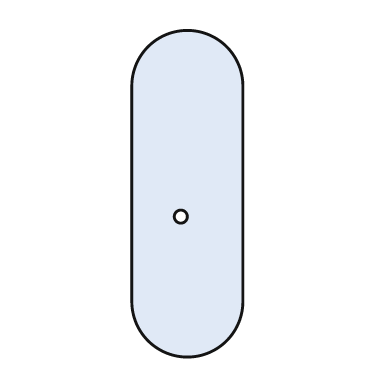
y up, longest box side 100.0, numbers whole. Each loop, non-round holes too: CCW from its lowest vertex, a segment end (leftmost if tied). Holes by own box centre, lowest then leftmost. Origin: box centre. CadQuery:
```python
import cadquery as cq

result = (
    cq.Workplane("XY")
    .moveTo(-17.0, -33.0)
    .threePointArc((0.0, -50.0), (17.0, -33.0))
    .lineTo(17.0, 33.0)
    .threePointArc((0.0, 50.0), (-17.0, 33.0))
    .close()
    .moveTo(-2.0, -7.0)
    .circle(2.0)
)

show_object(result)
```